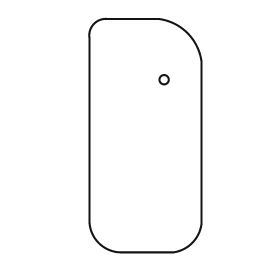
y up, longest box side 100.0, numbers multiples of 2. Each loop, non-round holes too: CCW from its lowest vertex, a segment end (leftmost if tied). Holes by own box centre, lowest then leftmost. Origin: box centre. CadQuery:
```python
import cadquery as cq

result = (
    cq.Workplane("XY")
    .moveTo(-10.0, -50.0)
    .lineTo(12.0, -50.0)
    .threePointArc((20.0, -46.0), (24.0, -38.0))
    .lineTo(24.0, 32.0)
    .threePointArc((18.0, 44.0), (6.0, 50.0))
    .lineTo(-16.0, 50.0)
    .threePointArc((-22.0, 48.0), (-24.0, 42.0))
    .lineTo(-24.0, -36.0)
    .threePointArc((-20.0, -46.0), (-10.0, -50.0))
    .close()
    .moveTo(8.0, 24.0)
    .circle(2.0)
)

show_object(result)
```